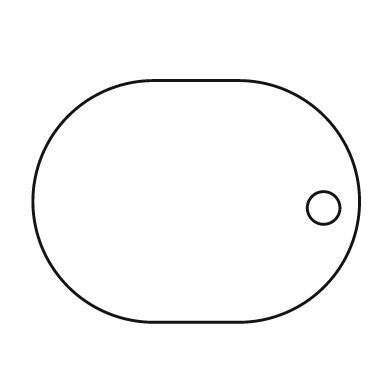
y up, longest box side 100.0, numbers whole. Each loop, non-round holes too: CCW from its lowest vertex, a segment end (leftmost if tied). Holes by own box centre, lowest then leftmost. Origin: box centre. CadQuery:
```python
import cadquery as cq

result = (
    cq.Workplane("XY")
    .moveTo(-13.0, -37.0)
    .lineTo(13.0, -37.0)
    .threePointArc((50.0, 0.0), (13.0, 37.0))
    .lineTo(-13.0, 37.0)
    .threePointArc((-50.0, 0.0), (-13.0, -37.0))
    .close()
    .moveTo(39.0, -2.0)
    .circle(5.0)
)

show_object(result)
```